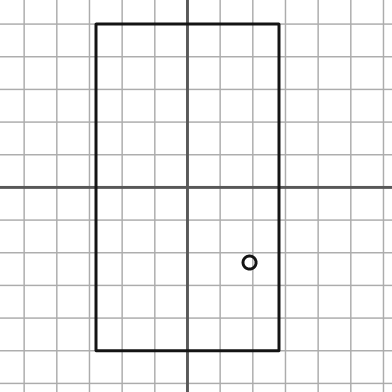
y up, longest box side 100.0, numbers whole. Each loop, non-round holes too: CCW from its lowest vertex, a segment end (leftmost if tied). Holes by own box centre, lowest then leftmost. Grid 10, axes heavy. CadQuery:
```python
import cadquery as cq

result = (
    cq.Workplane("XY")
    .moveTo(-28.0, -50.0)
    .lineTo(28.0, -50.0)
    .lineTo(28.0, 50.0)
    .lineTo(-28.0, 50.0)
    .close()
    .moveTo(19.0, -23.0)
    .circle(2.0)
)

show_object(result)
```